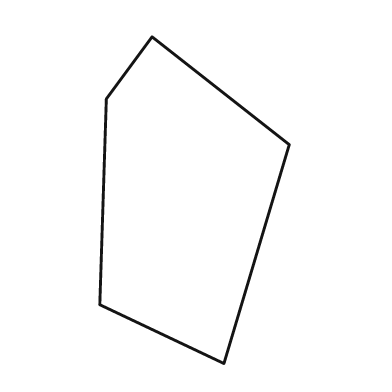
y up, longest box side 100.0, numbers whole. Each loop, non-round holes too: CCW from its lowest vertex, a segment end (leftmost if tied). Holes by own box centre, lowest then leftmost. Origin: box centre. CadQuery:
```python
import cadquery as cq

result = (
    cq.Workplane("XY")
    .moveTo(9.0, -50.0)
    .lineTo(29.0, 17.0)
    .lineTo(-13.0, 50.0)
    .lineTo(-27.0, 31.0)
    .lineTo(-29.0, -32.0)
    .close()
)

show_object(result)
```